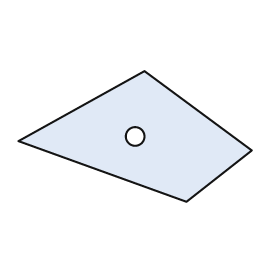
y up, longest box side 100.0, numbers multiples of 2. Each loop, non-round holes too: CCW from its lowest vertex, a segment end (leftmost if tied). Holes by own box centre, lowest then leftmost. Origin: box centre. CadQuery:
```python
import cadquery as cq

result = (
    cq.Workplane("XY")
    .moveTo(22.0, -28.0)
    .lineTo(50.0, -6.0)
    .lineTo(4.0, 28.0)
    .lineTo(-50.0, -2.0)
    .close()
    .moveTo(0.0, 0.0)
    .circle(4.0)
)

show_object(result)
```